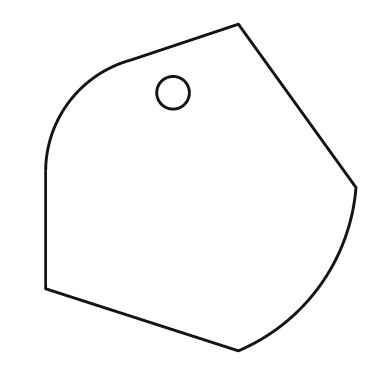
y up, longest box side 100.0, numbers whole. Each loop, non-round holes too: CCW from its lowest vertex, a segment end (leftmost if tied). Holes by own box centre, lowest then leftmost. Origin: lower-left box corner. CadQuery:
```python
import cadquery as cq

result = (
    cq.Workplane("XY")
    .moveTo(59.0, 0.0)
    .threePointArc((84.0, 20.0), (95.0, 50.0))
    .lineTo(59.0, 100.0)
    .lineTo(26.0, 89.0)
    .threePointArc((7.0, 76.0), (0.0, 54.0))
    .lineTo(0.0, 19.0)
    .close()
    .moveTo(39.0, 79.0)
    .circle(5.0)
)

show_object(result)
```